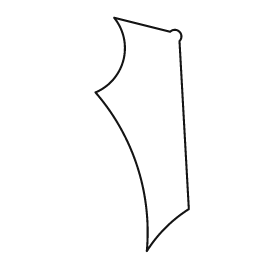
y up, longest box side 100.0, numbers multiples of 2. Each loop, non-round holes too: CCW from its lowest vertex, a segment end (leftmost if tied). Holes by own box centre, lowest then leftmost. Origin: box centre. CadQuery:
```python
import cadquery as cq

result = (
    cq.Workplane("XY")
    .moveTo(2.0, -50.0)
    .threePointArc((10.0, -40.0), (20.0, -32.0))
    .lineTo(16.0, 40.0)
    .threePointArc((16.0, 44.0), (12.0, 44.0))
    .lineTo(-12.0, 50.0)
    .threePointArc((-8.0, 32.0), (-20.0, 18.0))
    .threePointArc((-2.0, -14.0), (2.0, -50.0))
    .close()
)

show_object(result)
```